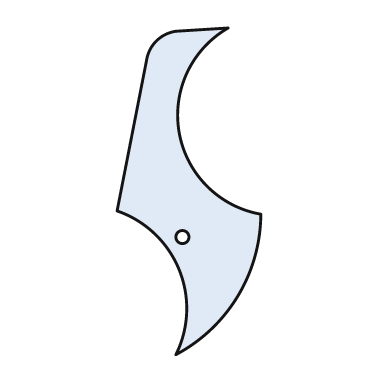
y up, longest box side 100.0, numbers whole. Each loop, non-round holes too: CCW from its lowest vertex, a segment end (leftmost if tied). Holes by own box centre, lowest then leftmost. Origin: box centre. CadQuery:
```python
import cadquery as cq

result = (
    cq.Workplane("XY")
    .moveTo(-4.0, -50.0)
    .threePointArc((15.0, -32.0), (22.0, -7.0))
    .threePointArc((-3.0, 18.0), (12.0, 50.0))
    .lineTo(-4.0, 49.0)
    .threePointArc((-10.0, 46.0), (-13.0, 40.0))
    .lineTo(-22.0, -6.0)
    .threePointArc((-3.0, -24.0), (-4.0, -50.0))
    .close()
    .moveTo(-2.0, -14.0)
    .circle(2.0)
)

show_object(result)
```